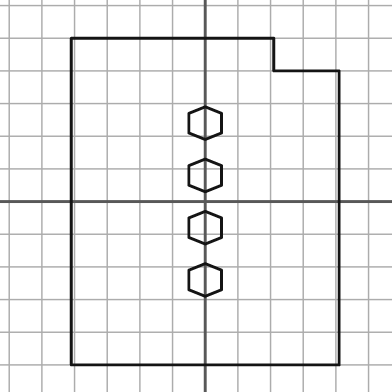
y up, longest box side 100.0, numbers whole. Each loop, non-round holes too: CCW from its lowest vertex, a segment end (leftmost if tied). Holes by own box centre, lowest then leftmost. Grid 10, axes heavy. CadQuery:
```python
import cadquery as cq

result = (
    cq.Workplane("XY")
    .moveTo(-41.0, -50.0)
    .lineTo(41.0, -50.0)
    .lineTo(41.0, 40.0)
    .lineTo(21.0, 40.0)
    .lineTo(21.0, 50.0)
    .lineTo(-41.0, 50.0)
    .close()
    .moveTo(0.0, -29.0)
    .lineTo(5.0, -27.0)
    .lineTo(5.0, -21.0)
    .lineTo(0.0, -19.0)
    .lineTo(-5.0, -21.0)
    .lineTo(-5.0, -27.0)
    .close()
    .moveTo(0.0, -13.0)
    .lineTo(5.0, -11.0)
    .lineTo(5.0, -5.0)
    .lineTo(0.0, -3.0)
    .lineTo(-5.0, -5.0)
    .lineTo(-5.0, -11.0)
    .close()
    .moveTo(0.0, 3.0)
    .lineTo(5.0, 5.0)
    .lineTo(5.0, 11.0)
    .lineTo(0.0, 13.0)
    .lineTo(-5.0, 11.0)
    .lineTo(-5.0, 5.0)
    .close()
    .moveTo(0.0, 19.0)
    .lineTo(5.0, 21.0)
    .lineTo(5.0, 27.0)
    .lineTo(0.0, 29.0)
    .lineTo(-5.0, 27.0)
    .lineTo(-5.0, 21.0)
    .close()
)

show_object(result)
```